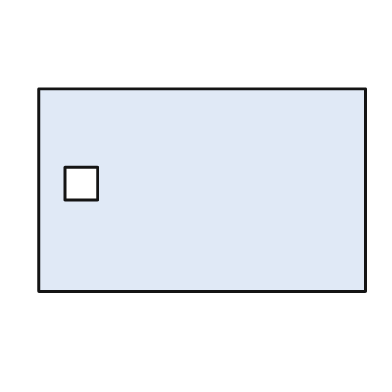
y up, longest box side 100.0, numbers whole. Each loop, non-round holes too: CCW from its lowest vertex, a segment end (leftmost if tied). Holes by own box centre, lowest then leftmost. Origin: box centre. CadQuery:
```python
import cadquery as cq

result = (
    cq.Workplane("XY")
    .moveTo(-50.0, -31.0)
    .lineTo(50.0, -31.0)
    .lineTo(50.0, 31.0)
    .lineTo(-50.0, 31.0)
    .close()
    .moveTo(-42.0, -3.0)
    .lineTo(-32.0, -3.0)
    .lineTo(-32.0, 7.0)
    .lineTo(-42.0, 7.0)
    .close()
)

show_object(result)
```